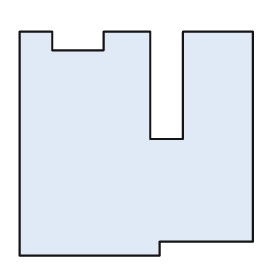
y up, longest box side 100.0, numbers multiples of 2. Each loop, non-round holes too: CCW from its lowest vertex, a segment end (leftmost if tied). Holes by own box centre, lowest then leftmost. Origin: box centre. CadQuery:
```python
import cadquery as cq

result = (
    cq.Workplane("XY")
    .moveTo(-50.0, -48.0)
    .lineTo(10.0, -48.0)
    .lineTo(10.0, -42.0)
    .lineTo(50.0, -42.0)
    .lineTo(50.0, 48.0)
    .lineTo(20.0, 48.0)
    .lineTo(20.0, 2.0)
    .lineTo(6.0, 2.0)
    .lineTo(6.0, 48.0)
    .lineTo(-14.0, 48.0)
    .lineTo(-14.0, 40.0)
    .lineTo(-36.0, 40.0)
    .lineTo(-36.0, 48.0)
    .lineTo(-50.0, 48.0)
    .close()
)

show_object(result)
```